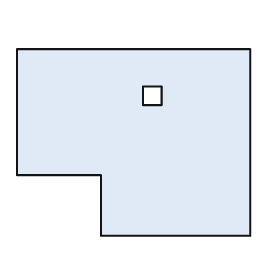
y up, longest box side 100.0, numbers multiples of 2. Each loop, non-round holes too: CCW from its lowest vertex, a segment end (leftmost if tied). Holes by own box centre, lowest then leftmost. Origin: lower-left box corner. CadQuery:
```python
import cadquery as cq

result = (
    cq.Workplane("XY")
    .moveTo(36.0, 0.0)
    .lineTo(100.0, 0.0)
    .lineTo(100.0, 80.0)
    .lineTo(0.0, 80.0)
    .lineTo(0.0, 26.0)
    .lineTo(36.0, 26.0)
    .close()
    .moveTo(54.0, 56.0)
    .lineTo(62.0, 56.0)
    .lineTo(62.0, 64.0)
    .lineTo(54.0, 64.0)
    .close()
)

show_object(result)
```